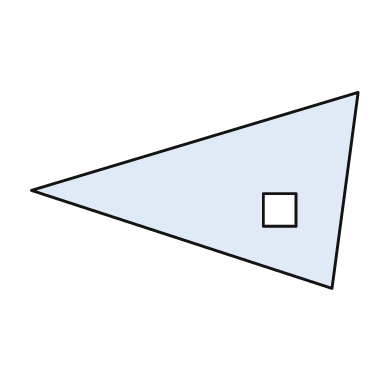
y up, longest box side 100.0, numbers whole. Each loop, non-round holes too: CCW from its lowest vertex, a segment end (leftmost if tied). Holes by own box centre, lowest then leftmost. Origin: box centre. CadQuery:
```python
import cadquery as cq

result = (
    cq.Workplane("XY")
    .moveTo(42.0, -30.0)
    .lineTo(50.0, 30.0)
    .lineTo(-50.0, 0.0)
    .close()
    .moveTo(21.0, -11.0)
    .lineTo(31.0, -11.0)
    .lineTo(31.0, -1.0)
    .lineTo(21.0, -1.0)
    .close()
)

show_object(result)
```